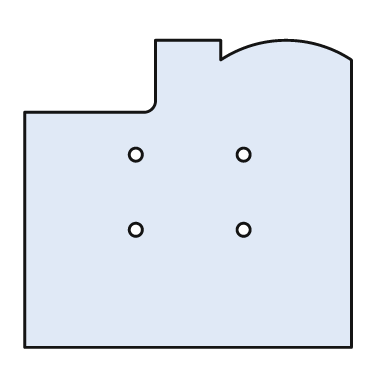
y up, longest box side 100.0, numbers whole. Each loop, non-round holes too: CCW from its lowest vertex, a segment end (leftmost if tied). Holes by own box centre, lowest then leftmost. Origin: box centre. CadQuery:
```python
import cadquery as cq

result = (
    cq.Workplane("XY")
    .moveTo(-50.0, -47.0)
    .lineTo(50.0, -47.0)
    .lineTo(50.0, 41.0)
    .threePointArc((30.0, 47.0), (10.0, 41.0))
    .lineTo(10.0, 47.0)
    .lineTo(-10.0, 47.0)
    .lineTo(-10.0, 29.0)
    .threePointArc((-11.0, 26.0), (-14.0, 25.0))
    .lineTo(-50.0, 25.0)
    .close()
    .moveTo(-16.0, -11.0)
    .circle(2.0)
    .moveTo(17.0, -11.0)
    .circle(2.0)
    .moveTo(-16.0, 12.0)
    .circle(2.0)
    .moveTo(17.0, 12.0)
    .circle(2.0)
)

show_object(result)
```